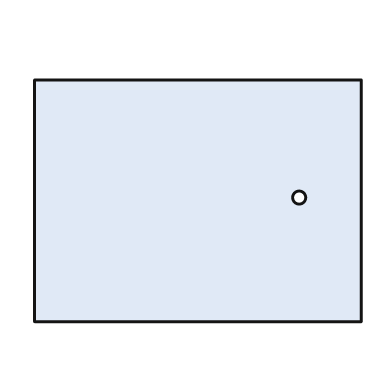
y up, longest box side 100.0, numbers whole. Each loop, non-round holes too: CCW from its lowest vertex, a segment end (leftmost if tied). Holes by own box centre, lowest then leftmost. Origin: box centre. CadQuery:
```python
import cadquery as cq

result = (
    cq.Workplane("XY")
    .moveTo(-50.0, -37.0)
    .lineTo(50.0, -37.0)
    .lineTo(50.0, 37.0)
    .lineTo(-50.0, 37.0)
    .close()
    .moveTo(31.0, 1.0)
    .circle(2.0)
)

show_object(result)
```